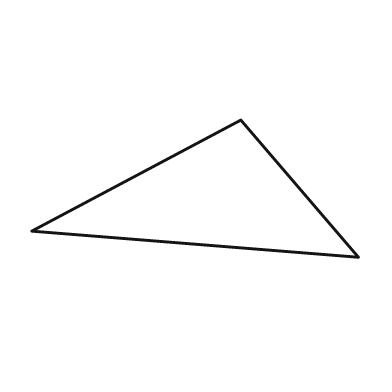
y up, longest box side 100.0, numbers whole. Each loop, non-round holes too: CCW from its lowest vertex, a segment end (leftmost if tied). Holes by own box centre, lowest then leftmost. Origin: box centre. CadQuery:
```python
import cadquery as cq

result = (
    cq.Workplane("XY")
    .moveTo(50.0, -21.0)
    .lineTo(14.0, 21.0)
    .lineTo(-50.0, -13.0)
    .close()
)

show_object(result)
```